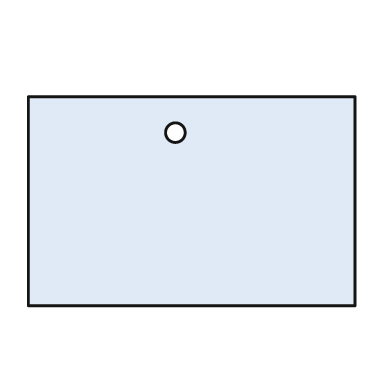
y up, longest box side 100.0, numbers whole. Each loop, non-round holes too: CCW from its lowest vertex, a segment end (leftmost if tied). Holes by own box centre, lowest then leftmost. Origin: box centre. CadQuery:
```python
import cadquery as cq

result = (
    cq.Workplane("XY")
    .moveTo(-50.0, -32.0)
    .lineTo(50.0, -32.0)
    .lineTo(50.0, 32.0)
    .lineTo(-50.0, 32.0)
    .close()
    .moveTo(-5.0, 21.0)
    .circle(3.0)
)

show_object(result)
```